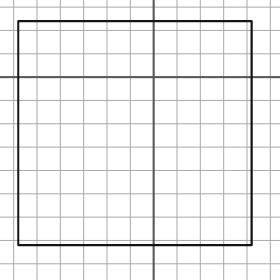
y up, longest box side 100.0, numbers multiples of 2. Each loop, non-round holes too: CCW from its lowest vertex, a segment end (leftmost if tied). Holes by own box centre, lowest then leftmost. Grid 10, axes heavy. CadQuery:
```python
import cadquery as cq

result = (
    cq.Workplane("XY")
    .moveTo(-58.0, -72.0)
    .lineTo(42.0, -72.0)
    .lineTo(42.0, 24.0)
    .lineTo(-58.0, 24.0)
    .close()
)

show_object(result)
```